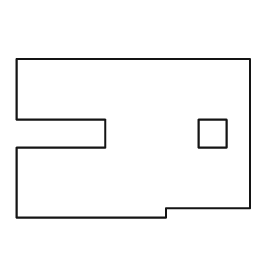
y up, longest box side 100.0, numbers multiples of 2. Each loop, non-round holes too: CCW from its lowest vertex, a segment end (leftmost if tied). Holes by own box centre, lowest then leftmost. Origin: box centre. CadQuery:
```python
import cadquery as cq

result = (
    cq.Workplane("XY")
    .moveTo(-50.0, -34.0)
    .lineTo(14.0, -34.0)
    .lineTo(14.0, -30.0)
    .lineTo(50.0, -30.0)
    .lineTo(50.0, 34.0)
    .lineTo(-50.0, 34.0)
    .lineTo(-50.0, 8.0)
    .lineTo(-12.0, 8.0)
    .lineTo(-12.0, -4.0)
    .lineTo(-50.0, -4.0)
    .close()
    .moveTo(28.0, -4.0)
    .lineTo(40.0, -4.0)
    .lineTo(40.0, 8.0)
    .lineTo(28.0, 8.0)
    .close()
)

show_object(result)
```